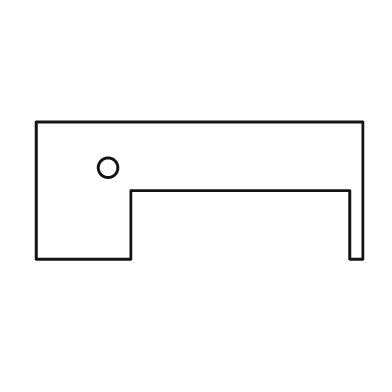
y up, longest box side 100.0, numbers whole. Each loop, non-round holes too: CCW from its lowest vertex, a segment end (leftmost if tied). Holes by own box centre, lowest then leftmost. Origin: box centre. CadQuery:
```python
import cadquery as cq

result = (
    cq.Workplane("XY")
    .moveTo(-50.0, -21.0)
    .lineTo(-21.0, -21.0)
    .lineTo(-21.0, 0.0)
    .lineTo(46.0, 0.0)
    .lineTo(46.0, -21.0)
    .lineTo(50.0, -21.0)
    .lineTo(50.0, 21.0)
    .lineTo(-50.0, 21.0)
    .close()
    .moveTo(-28.0, 7.0)
    .circle(3.0)
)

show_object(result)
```